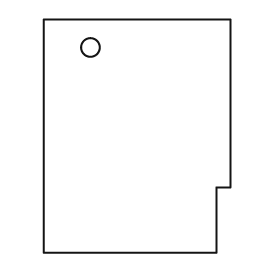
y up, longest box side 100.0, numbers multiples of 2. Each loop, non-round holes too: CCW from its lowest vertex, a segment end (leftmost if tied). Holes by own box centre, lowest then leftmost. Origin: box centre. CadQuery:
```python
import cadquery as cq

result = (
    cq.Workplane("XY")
    .moveTo(-40.0, -50.0)
    .lineTo(34.0, -50.0)
    .lineTo(34.0, -22.0)
    .lineTo(40.0, -22.0)
    .lineTo(40.0, 50.0)
    .lineTo(-40.0, 50.0)
    .close()
    .moveTo(-20.0, 38.0)
    .circle(4.0)
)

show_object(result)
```